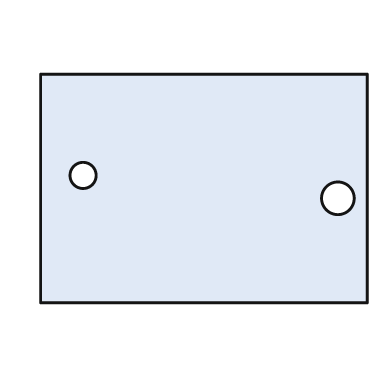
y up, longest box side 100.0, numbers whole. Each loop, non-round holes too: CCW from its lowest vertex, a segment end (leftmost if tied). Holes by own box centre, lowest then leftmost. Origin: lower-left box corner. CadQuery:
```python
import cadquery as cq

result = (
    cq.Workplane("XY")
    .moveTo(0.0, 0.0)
    .lineTo(100.0, 0.0)
    .lineTo(100.0, 70.0)
    .lineTo(0.0, 70.0)
    .close()
    .moveTo(91.0, 32.0)
    .circle(5.0)
    .moveTo(13.0, 39.0)
    .circle(4.0)
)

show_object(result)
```